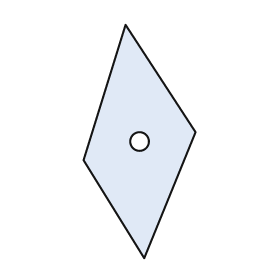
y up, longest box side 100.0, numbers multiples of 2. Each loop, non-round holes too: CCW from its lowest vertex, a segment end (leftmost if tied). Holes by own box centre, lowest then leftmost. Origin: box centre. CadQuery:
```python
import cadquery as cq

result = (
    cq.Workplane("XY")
    .moveTo(2.0, -50.0)
    .lineTo(24.0, 4.0)
    .lineTo(-6.0, 50.0)
    .lineTo(-24.0, -8.0)
    .close()
    .moveTo(0.0, 0.0)
    .circle(4.0)
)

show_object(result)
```